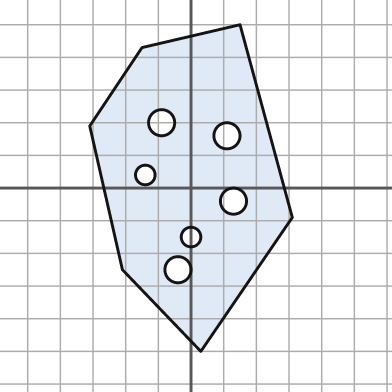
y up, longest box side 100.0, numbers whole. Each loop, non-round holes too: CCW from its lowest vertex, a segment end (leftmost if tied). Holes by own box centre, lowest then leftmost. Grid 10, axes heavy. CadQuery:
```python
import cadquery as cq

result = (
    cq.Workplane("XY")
    .moveTo(3.0, -50.0)
    .lineTo(31.0, -9.0)
    .lineTo(15.0, 50.0)
    .lineTo(-15.0, 43.0)
    .lineTo(-31.0, 19.0)
    .lineTo(-21.0, -25.0)
    .close()
    .moveTo(-4.0, -25.0)
    .circle(4.0)
    .moveTo(0.0, -15.0)
    .circle(3.0)
    .moveTo(13.0, -4.0)
    .circle(4.0)
    .moveTo(-14.0, 4.0)
    .circle(3.0)
    .moveTo(11.0, 16.0)
    .circle(4.0)
    .moveTo(-9.0, 20.0)
    .circle(4.0)
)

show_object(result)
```